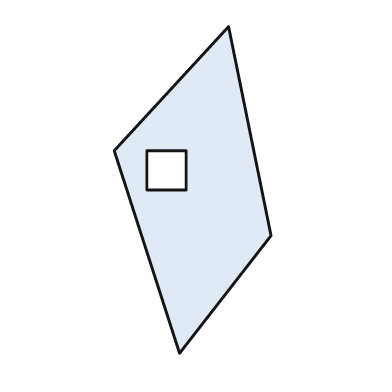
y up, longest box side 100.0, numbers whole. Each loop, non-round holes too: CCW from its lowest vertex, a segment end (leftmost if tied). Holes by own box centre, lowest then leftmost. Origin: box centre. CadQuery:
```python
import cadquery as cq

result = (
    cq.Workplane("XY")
    .moveTo(-4.0, -50.0)
    .lineTo(24.0, -14.0)
    .lineTo(11.0, 50.0)
    .lineTo(-24.0, 12.0)
    .close()
    .moveTo(-14.0, 0.0)
    .lineTo(-2.0, 0.0)
    .lineTo(-2.0, 12.0)
    .lineTo(-14.0, 12.0)
    .close()
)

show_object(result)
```